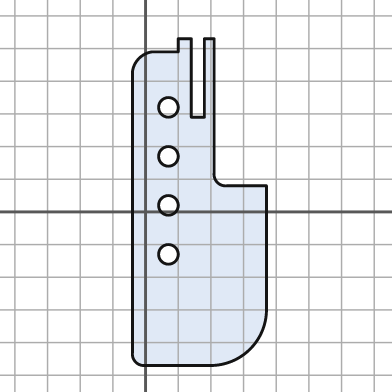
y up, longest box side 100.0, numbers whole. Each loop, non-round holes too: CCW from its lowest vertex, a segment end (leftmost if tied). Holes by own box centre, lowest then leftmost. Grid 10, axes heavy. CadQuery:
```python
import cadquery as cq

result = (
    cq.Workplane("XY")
    .moveTo(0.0, -47.0)
    .lineTo(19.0, -47.0)
    .threePointArc((32.0, -42.0), (37.0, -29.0))
    .lineTo(37.0, 8.0)
    .lineTo(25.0, 8.0)
    .threePointArc((22.0, 9.0), (21.0, 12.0))
    .lineTo(21.0, 53.0)
    .lineTo(18.0, 53.0)
    .lineTo(18.0, 29.0)
    .lineTo(14.0, 29.0)
    .lineTo(14.0, 53.0)
    .lineTo(10.0, 53.0)
    .lineTo(10.0, 49.0)
    .lineTo(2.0, 49.0)
    .threePointArc((-2.0, 47.0), (-4.0, 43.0))
    .lineTo(-4.0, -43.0)
    .threePointArc((-3.0, -46.0), (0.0, -47.0))
    .close()
    .moveTo(7.0, -13.0)
    .circle(3.0)
    .moveTo(7.0, 2.0)
    .circle(3.0)
    .moveTo(7.0, 17.0)
    .circle(3.0)
    .moveTo(7.0, 32.0)
    .circle(3.0)
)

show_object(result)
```